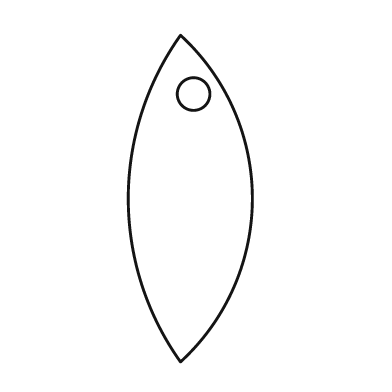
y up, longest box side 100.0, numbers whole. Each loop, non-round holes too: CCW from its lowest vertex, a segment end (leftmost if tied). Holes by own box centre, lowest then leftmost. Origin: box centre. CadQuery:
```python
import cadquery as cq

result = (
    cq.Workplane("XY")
    .moveTo(-3.0, -50.0)
    .threePointArc((19.0, 0.0), (-3.0, 50.0))
    .threePointArc((-19.0, 0.0), (-3.0, -50.0))
    .close()
    .moveTo(1.0, 32.0)
    .circle(5.0)
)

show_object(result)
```